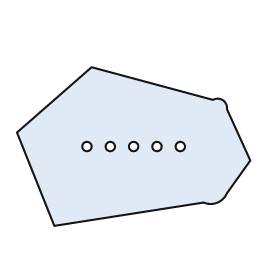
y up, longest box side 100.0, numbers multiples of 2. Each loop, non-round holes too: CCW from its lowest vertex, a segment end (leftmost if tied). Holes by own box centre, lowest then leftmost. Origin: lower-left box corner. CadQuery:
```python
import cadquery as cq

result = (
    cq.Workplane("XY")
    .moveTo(16.0, 0.0)
    .lineTo(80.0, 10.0)
    .threePointArc((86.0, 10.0), (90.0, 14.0))
    .lineTo(100.0, 28.0)
    .lineTo(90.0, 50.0)
    .threePointArc((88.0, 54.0), (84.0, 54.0))
    .lineTo(32.0, 68.0)
    .lineTo(0.0, 40.0)
    .close()
    .moveTo(30.0, 34.0)
    .circle(2.0)
    .moveTo(40.0, 34.0)
    .circle(2.0)
    .moveTo(50.0, 34.0)
    .circle(2.0)
    .moveTo(60.0, 34.0)
    .circle(2.0)
    .moveTo(70.0, 34.0)
    .circle(2.0)
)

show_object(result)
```